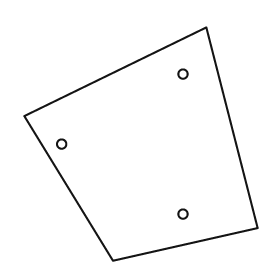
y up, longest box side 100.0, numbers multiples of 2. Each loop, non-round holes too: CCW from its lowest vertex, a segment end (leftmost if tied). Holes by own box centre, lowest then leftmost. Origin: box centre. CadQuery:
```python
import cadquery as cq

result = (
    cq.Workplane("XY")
    .moveTo(-12.0, -50.0)
    .lineTo(50.0, -36.0)
    .lineTo(28.0, 50.0)
    .lineTo(-50.0, 12.0)
    .close()
    .moveTo(18.0, -30.0)
    .circle(2.0)
    .moveTo(-34.0, 0.0)
    .circle(2.0)
    .moveTo(18.0, 30.0)
    .circle(2.0)
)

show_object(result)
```